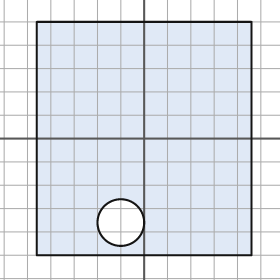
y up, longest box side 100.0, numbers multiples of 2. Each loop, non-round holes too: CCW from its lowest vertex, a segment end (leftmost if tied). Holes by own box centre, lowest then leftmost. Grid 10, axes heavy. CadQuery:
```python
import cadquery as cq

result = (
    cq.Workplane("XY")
    .moveTo(-46.0, -50.0)
    .lineTo(46.0, -50.0)
    .lineTo(46.0, 50.0)
    .lineTo(-46.0, 50.0)
    .close()
    .moveTo(-10.0, -36.0)
    .circle(10.0)
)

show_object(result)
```